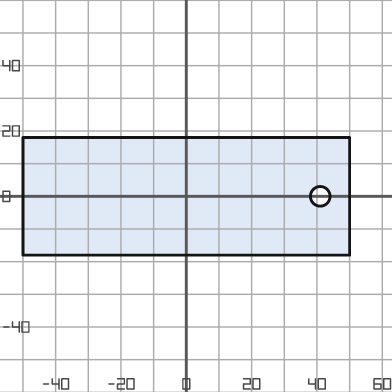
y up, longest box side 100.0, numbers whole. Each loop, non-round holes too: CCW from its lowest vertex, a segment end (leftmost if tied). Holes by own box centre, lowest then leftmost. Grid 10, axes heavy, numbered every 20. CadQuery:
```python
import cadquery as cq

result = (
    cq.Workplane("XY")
    .moveTo(-50.0, -18.0)
    .lineTo(50.0, -18.0)
    .lineTo(50.0, 18.0)
    .lineTo(-50.0, 18.0)
    .close()
    .moveTo(41.0, 0.0)
    .circle(3.0)
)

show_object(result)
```